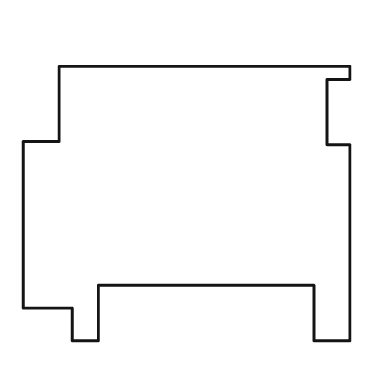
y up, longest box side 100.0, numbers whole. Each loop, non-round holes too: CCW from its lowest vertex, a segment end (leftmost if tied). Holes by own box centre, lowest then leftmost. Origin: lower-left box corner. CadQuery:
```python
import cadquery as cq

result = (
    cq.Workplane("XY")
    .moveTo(15.0, 0.0)
    .lineTo(23.0, 0.0)
    .lineTo(23.0, 17.0)
    .lineTo(89.0, 17.0)
    .lineTo(89.0, 0.0)
    .lineTo(100.0, 0.0)
    .lineTo(100.0, 60.0)
    .lineTo(93.0, 60.0)
    .lineTo(93.0, 80.0)
    .lineTo(100.0, 80.0)
    .lineTo(100.0, 84.0)
    .lineTo(11.0, 84.0)
    .lineTo(11.0, 61.0)
    .lineTo(0.0, 61.0)
    .lineTo(0.0, 10.0)
    .lineTo(15.0, 10.0)
    .close()
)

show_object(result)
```